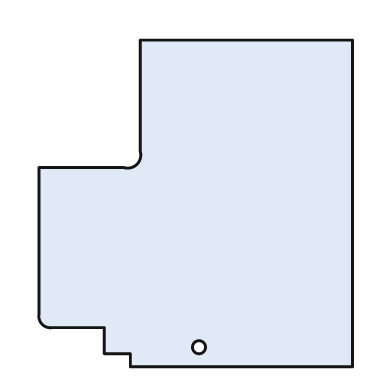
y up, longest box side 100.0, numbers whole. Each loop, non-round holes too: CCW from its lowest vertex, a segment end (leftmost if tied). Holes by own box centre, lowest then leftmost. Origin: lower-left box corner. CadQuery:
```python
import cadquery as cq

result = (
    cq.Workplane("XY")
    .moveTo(28.0, 0.0)
    .lineTo(96.0, 0.0)
    .lineTo(96.0, 100.0)
    .lineTo(31.0, 100.0)
    .lineTo(31.0, 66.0)
    .threePointArc((30.0, 62.0), (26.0, 61.0))
    .lineTo(0.0, 61.0)
    .lineTo(0.0, 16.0)
    .threePointArc((1.0, 13.0), (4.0, 12.0))
    .lineTo(20.0, 12.0)
    .lineTo(20.0, 4.0)
    .lineTo(28.0, 4.0)
    .close()
    .moveTo(49.0, 6.0)
    .circle(2.0)
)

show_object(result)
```